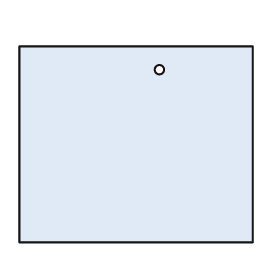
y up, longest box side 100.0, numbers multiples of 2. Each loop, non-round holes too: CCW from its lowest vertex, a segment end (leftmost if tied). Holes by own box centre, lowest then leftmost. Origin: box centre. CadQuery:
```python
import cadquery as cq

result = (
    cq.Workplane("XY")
    .moveTo(-50.0, -42.0)
    .lineTo(50.0, -42.0)
    .lineTo(50.0, 42.0)
    .lineTo(-50.0, 42.0)
    .close()
    .moveTo(10.0, 32.0)
    .circle(2.0)
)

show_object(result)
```